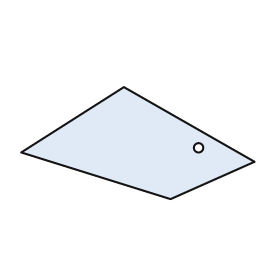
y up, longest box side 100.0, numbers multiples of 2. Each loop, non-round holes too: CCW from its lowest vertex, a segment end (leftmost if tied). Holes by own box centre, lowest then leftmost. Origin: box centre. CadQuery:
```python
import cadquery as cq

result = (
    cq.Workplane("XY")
    .moveTo(14.0, -24.0)
    .lineTo(50.0, -8.0)
    .lineTo(-6.0, 24.0)
    .lineTo(-50.0, -4.0)
    .close()
    .moveTo(26.0, -2.0)
    .circle(2.0)
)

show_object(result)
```